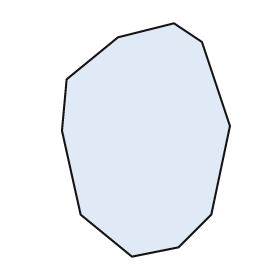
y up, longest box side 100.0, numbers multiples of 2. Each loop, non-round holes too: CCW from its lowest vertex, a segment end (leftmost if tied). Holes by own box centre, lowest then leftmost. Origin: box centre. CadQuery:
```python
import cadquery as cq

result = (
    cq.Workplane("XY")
    .moveTo(-6.0, -50.0)
    .lineTo(14.0, -46.0)
    .lineTo(28.0, -32.0)
    .lineTo(36.0, 6.0)
    .lineTo(24.0, 42.0)
    .lineTo(12.0, 50.0)
    .lineTo(-12.0, 44.0)
    .lineTo(-34.0, 26.0)
    .lineTo(-36.0, 4.0)
    .lineTo(-28.0, -32.0)
    .close()
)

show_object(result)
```